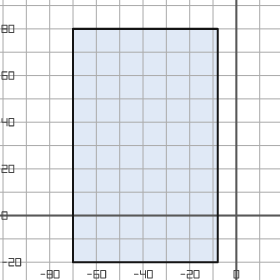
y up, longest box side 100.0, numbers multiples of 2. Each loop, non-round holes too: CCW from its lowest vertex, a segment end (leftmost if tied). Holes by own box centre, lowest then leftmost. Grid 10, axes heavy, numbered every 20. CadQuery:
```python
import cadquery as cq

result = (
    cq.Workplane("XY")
    .moveTo(-70.0, -20.0)
    .lineTo(-8.0, -20.0)
    .lineTo(-8.0, 80.0)
    .lineTo(-70.0, 80.0)
    .close()
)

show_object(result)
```